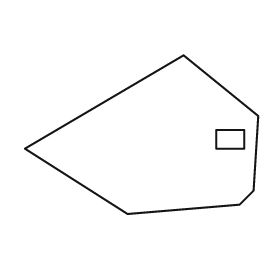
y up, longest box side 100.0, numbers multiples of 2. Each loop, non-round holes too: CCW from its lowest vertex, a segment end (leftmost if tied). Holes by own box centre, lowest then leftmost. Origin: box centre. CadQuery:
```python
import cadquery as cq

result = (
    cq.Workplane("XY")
    .moveTo(-6.0, -34.0)
    .lineTo(42.0, -30.0)
    .lineTo(48.0, -24.0)
    .lineTo(50.0, 8.0)
    .lineTo(18.0, 34.0)
    .lineTo(-50.0, -6.0)
    .close()
    .moveTo(32.0, -6.0)
    .lineTo(44.0, -6.0)
    .lineTo(44.0, 2.0)
    .lineTo(32.0, 2.0)
    .close()
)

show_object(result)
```